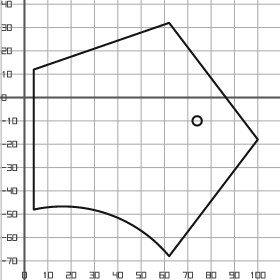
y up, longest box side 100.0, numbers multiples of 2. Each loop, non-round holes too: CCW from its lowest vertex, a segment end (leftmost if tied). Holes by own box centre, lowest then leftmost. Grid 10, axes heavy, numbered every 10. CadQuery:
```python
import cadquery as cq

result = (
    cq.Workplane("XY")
    .moveTo(62.0, -68.0)
    .lineTo(100.0, -18.0)
    .lineTo(62.0, 32.0)
    .lineTo(4.0, 12.0)
    .lineTo(4.0, -48.0)
    .threePointArc((36.0, -50.0), (62.0, -68.0))
    .close()
    .moveTo(74.0, -10.0)
    .circle(2.0)
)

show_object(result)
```